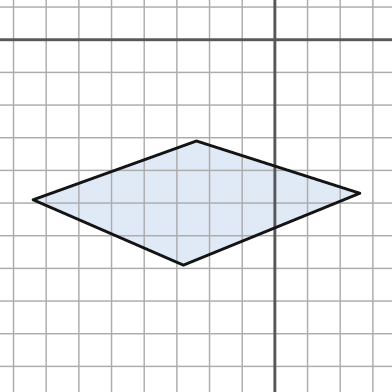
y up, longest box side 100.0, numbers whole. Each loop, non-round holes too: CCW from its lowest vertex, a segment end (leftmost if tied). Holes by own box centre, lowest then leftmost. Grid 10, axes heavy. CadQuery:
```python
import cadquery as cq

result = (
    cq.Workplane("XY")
    .moveTo(-28.0, -69.0)
    .lineTo(26.0, -47.0)
    .lineTo(-24.0, -31.0)
    .lineTo(-74.0, -49.0)
    .close()
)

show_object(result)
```